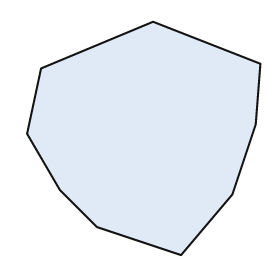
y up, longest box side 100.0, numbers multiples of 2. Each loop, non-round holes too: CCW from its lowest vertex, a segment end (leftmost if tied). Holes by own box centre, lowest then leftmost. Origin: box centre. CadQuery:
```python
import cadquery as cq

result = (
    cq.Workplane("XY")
    .moveTo(16.0, -50.0)
    .lineTo(38.0, -24.0)
    .lineTo(48.0, 6.0)
    .lineTo(50.0, 32.0)
    .lineTo(4.0, 50.0)
    .lineTo(-44.0, 30.0)
    .lineTo(-50.0, 2.0)
    .lineTo(-36.0, -22.0)
    .lineTo(-20.0, -38.0)
    .close()
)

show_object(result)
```